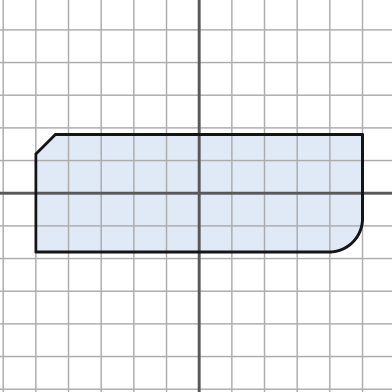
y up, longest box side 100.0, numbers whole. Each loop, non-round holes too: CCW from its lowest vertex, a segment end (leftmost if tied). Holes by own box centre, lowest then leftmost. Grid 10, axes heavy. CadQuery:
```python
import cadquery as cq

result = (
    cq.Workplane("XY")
    .moveTo(-50.0, -18.0)
    .lineTo(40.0, -18.0)
    .threePointArc((47.0, -15.0), (50.0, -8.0))
    .lineTo(50.0, 18.0)
    .lineTo(-44.0, 18.0)
    .lineTo(-50.0, 12.0)
    .close()
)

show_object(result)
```